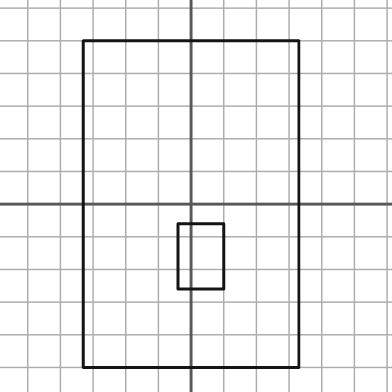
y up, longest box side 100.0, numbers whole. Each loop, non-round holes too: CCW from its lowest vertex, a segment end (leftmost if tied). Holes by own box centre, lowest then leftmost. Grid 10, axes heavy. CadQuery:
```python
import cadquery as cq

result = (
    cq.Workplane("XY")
    .moveTo(-33.0, -50.0)
    .lineTo(33.0, -50.0)
    .lineTo(33.0, 50.0)
    .lineTo(-33.0, 50.0)
    .close()
    .moveTo(-4.0, -26.0)
    .lineTo(10.0, -26.0)
    .lineTo(10.0, -6.0)
    .lineTo(-4.0, -6.0)
    .close()
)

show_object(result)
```